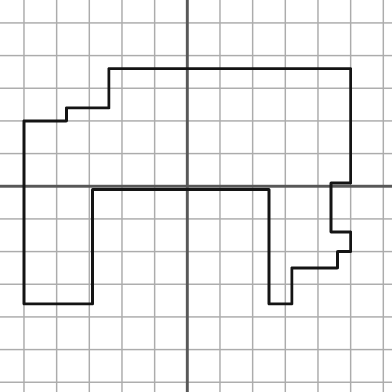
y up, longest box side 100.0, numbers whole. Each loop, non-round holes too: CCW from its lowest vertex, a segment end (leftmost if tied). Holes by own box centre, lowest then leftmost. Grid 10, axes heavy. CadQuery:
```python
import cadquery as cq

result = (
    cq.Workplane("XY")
    .moveTo(-50.0, -36.0)
    .lineTo(-29.0, -36.0)
    .lineTo(-29.0, -1.0)
    .lineTo(25.0, -1.0)
    .lineTo(25.0, -36.0)
    .lineTo(32.0, -36.0)
    .lineTo(32.0, -25.0)
    .lineTo(46.0, -25.0)
    .lineTo(46.0, -20.0)
    .lineTo(50.0, -20.0)
    .lineTo(50.0, -14.0)
    .lineTo(44.0, -14.0)
    .lineTo(44.0, 1.0)
    .lineTo(50.0, 1.0)
    .lineTo(50.0, 36.0)
    .lineTo(-24.0, 36.0)
    .lineTo(-24.0, 24.0)
    .lineTo(-37.0, 24.0)
    .lineTo(-37.0, 20.0)
    .lineTo(-50.0, 20.0)
    .close()
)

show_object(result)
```